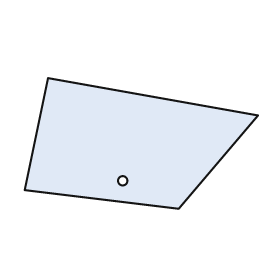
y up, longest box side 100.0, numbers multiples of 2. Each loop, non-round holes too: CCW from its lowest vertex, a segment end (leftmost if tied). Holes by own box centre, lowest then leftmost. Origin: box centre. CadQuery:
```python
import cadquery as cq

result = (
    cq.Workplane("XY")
    .moveTo(16.0, -28.0)
    .lineTo(50.0, 12.0)
    .lineTo(-40.0, 28.0)
    .lineTo(-50.0, -20.0)
    .close()
    .moveTo(-8.0, -16.0)
    .circle(2.0)
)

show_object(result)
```